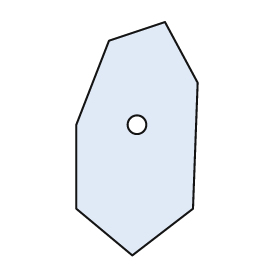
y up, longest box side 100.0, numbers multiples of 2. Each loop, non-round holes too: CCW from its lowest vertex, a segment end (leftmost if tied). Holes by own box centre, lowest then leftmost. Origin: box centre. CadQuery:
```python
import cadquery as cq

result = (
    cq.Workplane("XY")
    .moveTo(-2.0, -50.0)
    .lineTo(24.0, -30.0)
    .lineTo(26.0, 24.0)
    .lineTo(12.0, 50.0)
    .lineTo(-12.0, 42.0)
    .lineTo(-26.0, 6.0)
    .lineTo(-26.0, -30.0)
    .close()
    .moveTo(0.0, 6.0)
    .circle(4.0)
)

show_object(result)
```